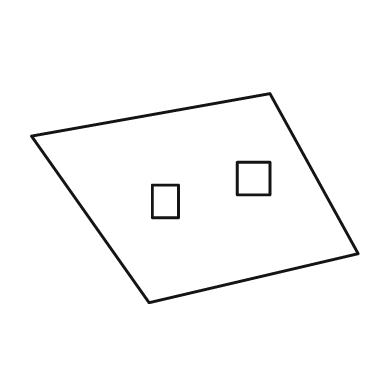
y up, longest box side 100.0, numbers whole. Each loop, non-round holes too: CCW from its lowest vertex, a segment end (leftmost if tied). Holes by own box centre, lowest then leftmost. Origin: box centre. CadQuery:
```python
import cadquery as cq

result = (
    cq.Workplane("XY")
    .moveTo(-14.0, -32.0)
    .lineTo(50.0, -17.0)
    .lineTo(23.0, 32.0)
    .lineTo(-50.0, 19.0)
    .close()
    .moveTo(-13.0, -6.0)
    .lineTo(-5.0, -6.0)
    .lineTo(-5.0, 4.0)
    .lineTo(-13.0, 4.0)
    .close()
    .moveTo(13.0, 1.0)
    .lineTo(23.0, 1.0)
    .lineTo(23.0, 11.0)
    .lineTo(13.0, 11.0)
    .close()
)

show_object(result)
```